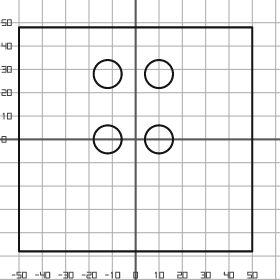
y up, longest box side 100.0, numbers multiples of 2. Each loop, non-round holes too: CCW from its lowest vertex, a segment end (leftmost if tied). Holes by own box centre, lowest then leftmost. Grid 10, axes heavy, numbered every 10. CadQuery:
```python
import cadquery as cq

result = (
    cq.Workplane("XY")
    .moveTo(-50.0, -48.0)
    .lineTo(50.0, -48.0)
    .lineTo(50.0, 48.0)
    .lineTo(-50.0, 48.0)
    .close()
    .moveTo(-12.0, 0.0)
    .circle(6.0)
    .moveTo(10.0, 0.0)
    .circle(6.0)
    .moveTo(-12.0, 28.0)
    .circle(6.0)
    .moveTo(10.0, 28.0)
    .circle(6.0)
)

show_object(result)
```